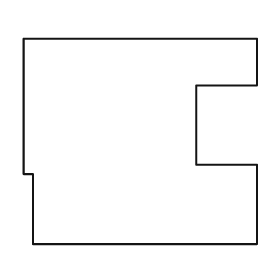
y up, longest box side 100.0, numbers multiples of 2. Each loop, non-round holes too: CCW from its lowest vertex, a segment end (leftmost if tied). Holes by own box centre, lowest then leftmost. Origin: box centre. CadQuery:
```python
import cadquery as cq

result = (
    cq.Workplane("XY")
    .moveTo(-46.0, -44.0)
    .lineTo(50.0, -44.0)
    .lineTo(50.0, -10.0)
    .lineTo(24.0, -10.0)
    .lineTo(24.0, 24.0)
    .lineTo(50.0, 24.0)
    .lineTo(50.0, 44.0)
    .lineTo(-50.0, 44.0)
    .lineTo(-50.0, -14.0)
    .lineTo(-46.0, -14.0)
    .close()
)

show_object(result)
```